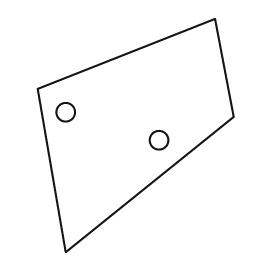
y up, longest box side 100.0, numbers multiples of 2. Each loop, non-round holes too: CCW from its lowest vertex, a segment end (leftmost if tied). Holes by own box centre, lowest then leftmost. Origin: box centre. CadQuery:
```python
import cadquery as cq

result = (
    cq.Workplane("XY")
    .moveTo(-30.0, -50.0)
    .lineTo(42.0, 8.0)
    .lineTo(34.0, 50.0)
    .lineTo(-42.0, 20.0)
    .close()
    .moveTo(10.0, -2.0)
    .circle(4.0)
    .moveTo(-30.0, 10.0)
    .circle(4.0)
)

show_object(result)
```